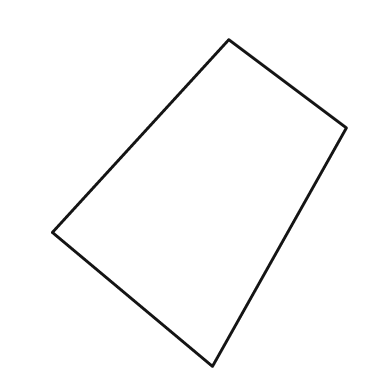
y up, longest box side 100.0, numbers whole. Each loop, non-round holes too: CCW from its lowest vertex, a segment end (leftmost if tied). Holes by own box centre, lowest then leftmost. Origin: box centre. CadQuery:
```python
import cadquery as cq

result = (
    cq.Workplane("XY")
    .moveTo(4.0, -50.0)
    .lineTo(45.0, 23.0)
    .lineTo(9.0, 50.0)
    .lineTo(-45.0, -9.0)
    .close()
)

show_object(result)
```